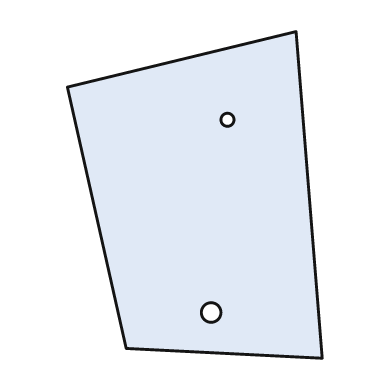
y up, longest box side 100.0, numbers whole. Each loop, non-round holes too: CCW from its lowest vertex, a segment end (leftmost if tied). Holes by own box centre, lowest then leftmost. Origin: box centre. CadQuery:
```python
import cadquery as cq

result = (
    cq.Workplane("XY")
    .moveTo(39.0, -50.0)
    .lineTo(31.0, 50.0)
    .lineTo(-39.0, 33.0)
    .lineTo(-21.0, -47.0)
    .close()
    .moveTo(5.0, -36.0)
    .circle(3.0)
    .moveTo(10.0, 23.0)
    .circle(2.0)
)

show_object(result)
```